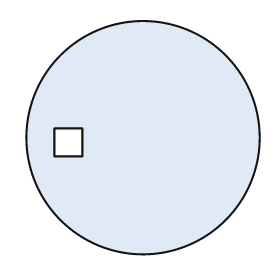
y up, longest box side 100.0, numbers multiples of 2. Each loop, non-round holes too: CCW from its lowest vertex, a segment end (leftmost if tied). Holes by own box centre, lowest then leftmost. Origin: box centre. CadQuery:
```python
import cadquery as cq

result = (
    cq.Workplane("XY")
    .moveTo(0.0, 0.0)
    .circle(50.0)
    .moveTo(-38.0, -8.0)
    .lineTo(-26.0, -8.0)
    .lineTo(-26.0, 4.0)
    .lineTo(-38.0, 4.0)
    .close()
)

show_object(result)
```